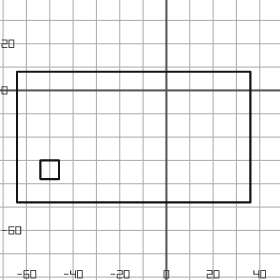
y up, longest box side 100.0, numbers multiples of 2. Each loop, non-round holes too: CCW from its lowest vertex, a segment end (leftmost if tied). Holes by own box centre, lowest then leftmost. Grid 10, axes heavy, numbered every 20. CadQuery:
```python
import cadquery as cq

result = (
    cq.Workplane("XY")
    .moveTo(-64.0, -48.0)
    .lineTo(36.0, -48.0)
    .lineTo(36.0, 8.0)
    .lineTo(-64.0, 8.0)
    .close()
    .moveTo(-54.0, -38.0)
    .lineTo(-46.0, -38.0)
    .lineTo(-46.0, -30.0)
    .lineTo(-54.0, -30.0)
    .close()
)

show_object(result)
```